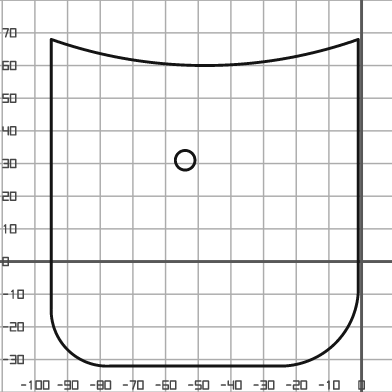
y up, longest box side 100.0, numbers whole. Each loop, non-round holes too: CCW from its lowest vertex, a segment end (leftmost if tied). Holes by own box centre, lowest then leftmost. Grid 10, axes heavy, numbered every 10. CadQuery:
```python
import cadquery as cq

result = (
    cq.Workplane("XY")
    .moveTo(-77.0, -32.0)
    .lineTo(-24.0, -32.0)
    .threePointArc((-8.0, -25.0), (-1.0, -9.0))
    .lineTo(-1.0, 68.0)
    .threePointArc((-48.0, 60.0), (-95.0, 68.0))
    .lineTo(-95.0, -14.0)
    .threePointArc((-90.0, -27.0), (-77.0, -32.0))
    .close()
    .moveTo(-54.0, 31.0)
    .circle(3.0)
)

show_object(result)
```